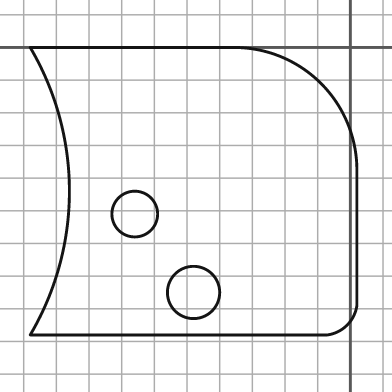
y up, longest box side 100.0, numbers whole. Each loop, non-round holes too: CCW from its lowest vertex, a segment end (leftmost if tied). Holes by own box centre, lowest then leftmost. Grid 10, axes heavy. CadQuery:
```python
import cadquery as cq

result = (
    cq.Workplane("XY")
    .moveTo(-98.0, -88.0)
    .lineTo(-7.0, -88.0)
    .threePointArc((-1.0, -85.0), (2.0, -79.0))
    .lineTo(2.0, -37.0)
    .threePointArc((-9.0, -11.0), (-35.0, 0.0))
    .lineTo(-98.0, 0.0)
    .threePointArc((-86.0, -44.0), (-98.0, -88.0))
    .close()
    .moveTo(-48.0, -75.0)
    .circle(8.0)
    .moveTo(-66.0, -51.0)
    .circle(7.0)
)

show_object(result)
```